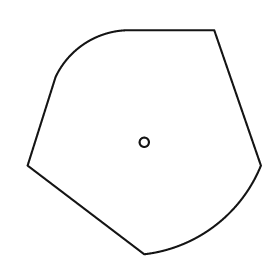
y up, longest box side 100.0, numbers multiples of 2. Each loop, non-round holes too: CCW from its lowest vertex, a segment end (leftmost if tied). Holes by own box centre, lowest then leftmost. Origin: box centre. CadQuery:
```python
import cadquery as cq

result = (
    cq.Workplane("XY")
    .moveTo(0.0, -48.0)
    .threePointArc((30.0, -36.0), (50.0, -10.0))
    .lineTo(30.0, 48.0)
    .lineTo(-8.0, 48.0)
    .threePointArc((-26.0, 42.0), (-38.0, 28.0))
    .lineTo(-50.0, -10.0)
    .close()
    .moveTo(0.0, 0.0)
    .circle(2.0)
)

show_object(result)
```